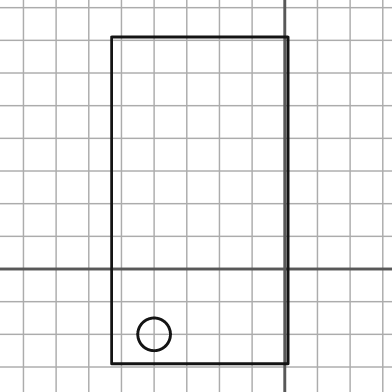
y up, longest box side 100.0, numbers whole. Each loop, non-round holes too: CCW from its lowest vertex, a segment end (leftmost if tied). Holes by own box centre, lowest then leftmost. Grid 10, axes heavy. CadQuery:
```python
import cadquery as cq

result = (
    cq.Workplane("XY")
    .moveTo(-53.0, -29.0)
    .lineTo(1.0, -29.0)
    .lineTo(1.0, 71.0)
    .lineTo(-53.0, 71.0)
    .close()
    .moveTo(-40.0, -20.0)
    .circle(5.0)
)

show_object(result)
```